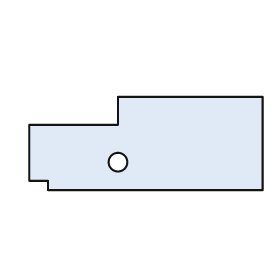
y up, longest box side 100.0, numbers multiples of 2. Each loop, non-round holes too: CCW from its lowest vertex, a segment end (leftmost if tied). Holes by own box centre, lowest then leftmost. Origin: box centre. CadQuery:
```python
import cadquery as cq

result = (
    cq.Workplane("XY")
    .moveTo(-42.0, -20.0)
    .lineTo(50.0, -20.0)
    .lineTo(50.0, 20.0)
    .lineTo(-12.0, 20.0)
    .lineTo(-12.0, 8.0)
    .lineTo(-50.0, 8.0)
    .lineTo(-50.0, -16.0)
    .lineTo(-42.0, -16.0)
    .close()
    .moveTo(-12.0, -8.0)
    .circle(4.0)
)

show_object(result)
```